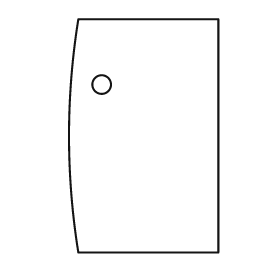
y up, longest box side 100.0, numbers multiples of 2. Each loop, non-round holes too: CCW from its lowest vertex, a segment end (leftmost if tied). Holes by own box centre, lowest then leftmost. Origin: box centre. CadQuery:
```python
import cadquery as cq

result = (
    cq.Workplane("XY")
    .moveTo(-28.0, -50.0)
    .lineTo(32.0, -50.0)
    .lineTo(32.0, 50.0)
    .lineTo(-28.0, 50.0)
    .threePointArc((-32.0, 0.0), (-28.0, -50.0))
    .close()
    .moveTo(-18.0, 22.0)
    .circle(4.0)
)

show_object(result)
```